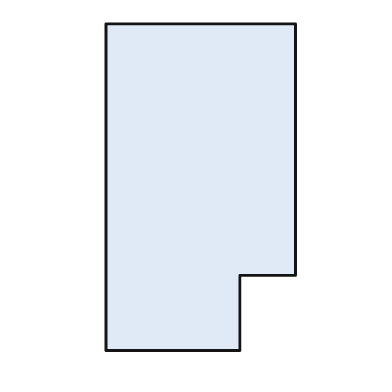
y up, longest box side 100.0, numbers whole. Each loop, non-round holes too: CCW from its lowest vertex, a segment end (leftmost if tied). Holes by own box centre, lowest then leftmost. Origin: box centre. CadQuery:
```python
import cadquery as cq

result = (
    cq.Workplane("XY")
    .moveTo(-29.0, -50.0)
    .lineTo(12.0, -50.0)
    .lineTo(12.0, -27.0)
    .lineTo(29.0, -27.0)
    .lineTo(29.0, 50.0)
    .lineTo(-29.0, 50.0)
    .close()
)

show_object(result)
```